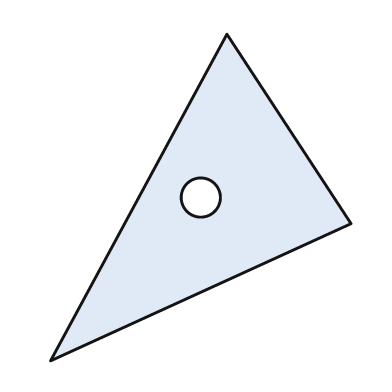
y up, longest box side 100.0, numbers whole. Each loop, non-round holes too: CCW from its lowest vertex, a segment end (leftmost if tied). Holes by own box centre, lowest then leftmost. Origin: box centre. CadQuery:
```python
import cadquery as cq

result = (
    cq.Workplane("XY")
    .moveTo(-46.0, -50.0)
    .lineTo(46.0, -8.0)
    .lineTo(8.0, 50.0)
    .close()
    .moveTo(0.0, 0.0)
    .circle(6.0)
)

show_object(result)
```